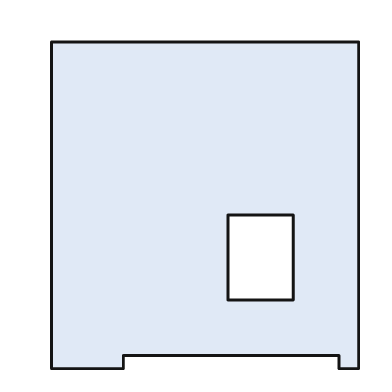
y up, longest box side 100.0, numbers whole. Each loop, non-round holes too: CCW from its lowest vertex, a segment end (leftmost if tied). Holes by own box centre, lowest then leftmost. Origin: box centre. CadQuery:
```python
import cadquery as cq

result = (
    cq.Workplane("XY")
    .moveTo(-47.0, -50.0)
    .lineTo(-25.0, -50.0)
    .lineTo(-25.0, -46.0)
    .lineTo(41.0, -46.0)
    .lineTo(41.0, -50.0)
    .lineTo(47.0, -50.0)
    .lineTo(47.0, 50.0)
    .lineTo(-47.0, 50.0)
    .close()
    .moveTo(7.0, -29.0)
    .lineTo(27.0, -29.0)
    .lineTo(27.0, -3.0)
    .lineTo(7.0, -3.0)
    .close()
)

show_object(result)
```